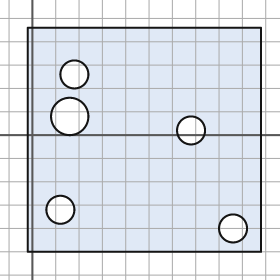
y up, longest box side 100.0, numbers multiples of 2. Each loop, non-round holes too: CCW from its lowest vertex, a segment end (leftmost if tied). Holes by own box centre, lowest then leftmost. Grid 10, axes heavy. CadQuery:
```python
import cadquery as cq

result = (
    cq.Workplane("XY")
    .moveTo(-2.0, -50.0)
    .lineTo(98.0, -50.0)
    .lineTo(98.0, 46.0)
    .lineTo(-2.0, 46.0)
    .close()
    .moveTo(86.0, -40.0)
    .circle(6.0)
    .moveTo(12.0, -32.0)
    .circle(6.0)
    .moveTo(68.0, 2.0)
    .circle(6.0)
    .moveTo(16.0, 8.0)
    .circle(8.0)
    .moveTo(18.0, 26.0)
    .circle(6.0)
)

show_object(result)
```